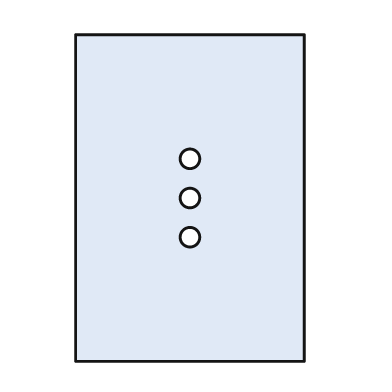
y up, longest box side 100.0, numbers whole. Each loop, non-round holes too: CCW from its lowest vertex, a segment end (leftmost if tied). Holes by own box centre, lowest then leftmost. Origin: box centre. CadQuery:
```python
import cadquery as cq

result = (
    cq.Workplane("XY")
    .moveTo(-35.0, -50.0)
    .lineTo(35.0, -50.0)
    .lineTo(35.0, 50.0)
    .lineTo(-35.0, 50.0)
    .close()
    .moveTo(0.0, -12.0)
    .circle(3.0)
    .moveTo(0.0, 0.0)
    .circle(3.0)
    .moveTo(0.0, 12.0)
    .circle(3.0)
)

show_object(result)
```